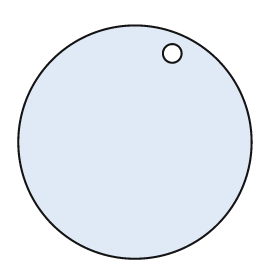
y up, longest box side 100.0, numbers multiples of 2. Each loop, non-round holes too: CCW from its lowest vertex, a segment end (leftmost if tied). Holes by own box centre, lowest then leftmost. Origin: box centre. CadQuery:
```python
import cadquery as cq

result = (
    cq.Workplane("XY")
    .moveTo(0.0, 0.0)
    .circle(50.0)
    .moveTo(16.0, 38.0)
    .circle(4.0)
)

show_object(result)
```